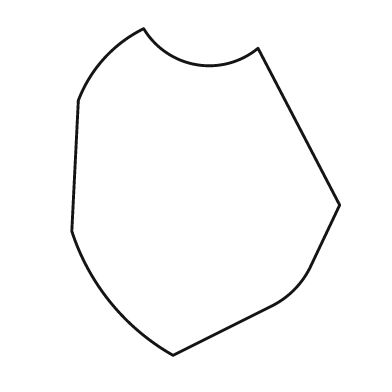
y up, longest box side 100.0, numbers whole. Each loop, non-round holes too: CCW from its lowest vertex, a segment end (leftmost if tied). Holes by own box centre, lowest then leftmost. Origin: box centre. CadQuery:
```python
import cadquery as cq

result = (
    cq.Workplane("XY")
    .moveTo(-10.0, -50.0)
    .lineTo(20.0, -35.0)
    .threePointArc((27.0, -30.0), (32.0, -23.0))
    .lineTo(41.0, -4.0)
    .lineTo(16.0, 44.0)
    .threePointArc((-3.0, 39.0), (-19.0, 50.0))
    .threePointArc((-31.0, 41.0), (-39.0, 28.0))
    .lineTo(-41.0, -12.0)
    .threePointArc((-29.0, -34.0), (-10.0, -50.0))
    .close()
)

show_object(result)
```